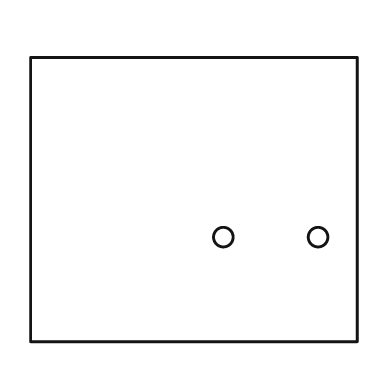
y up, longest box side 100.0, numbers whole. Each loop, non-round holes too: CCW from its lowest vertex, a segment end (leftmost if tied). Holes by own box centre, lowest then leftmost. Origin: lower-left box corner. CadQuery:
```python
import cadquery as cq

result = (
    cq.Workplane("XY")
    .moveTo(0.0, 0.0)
    .lineTo(100.0, 0.0)
    .lineTo(100.0, 87.0)
    .lineTo(0.0, 87.0)
    .close()
    .moveTo(59.0, 32.0)
    .circle(3.0)
    .moveTo(88.0, 32.0)
    .circle(3.0)
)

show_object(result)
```